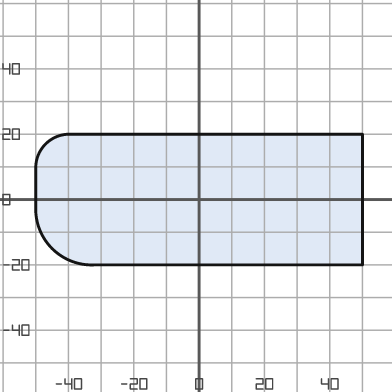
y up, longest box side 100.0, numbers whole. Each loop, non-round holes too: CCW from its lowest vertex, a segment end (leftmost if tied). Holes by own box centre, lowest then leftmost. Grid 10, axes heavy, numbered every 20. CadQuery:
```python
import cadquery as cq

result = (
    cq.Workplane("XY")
    .moveTo(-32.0, -20.0)
    .lineTo(50.0, -20.0)
    .lineTo(50.0, 20.0)
    .lineTo(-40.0, 20.0)
    .threePointArc((-47.0, 17.0), (-50.0, 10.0))
    .lineTo(-50.0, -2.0)
    .threePointArc((-45.0, -15.0), (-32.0, -20.0))
    .close()
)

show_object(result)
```